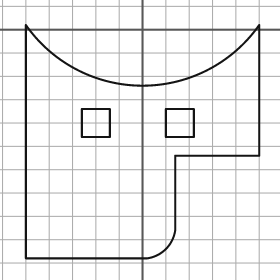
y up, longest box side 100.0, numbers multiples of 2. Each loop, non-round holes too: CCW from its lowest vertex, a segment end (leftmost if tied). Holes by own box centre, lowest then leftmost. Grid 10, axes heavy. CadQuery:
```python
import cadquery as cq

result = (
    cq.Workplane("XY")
    .moveTo(-50.0, -98.0)
    .lineTo(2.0, -98.0)
    .threePointArc((10.0, -94.0), (14.0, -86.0))
    .lineTo(14.0, -54.0)
    .lineTo(50.0, -54.0)
    .lineTo(50.0, 2.0)
    .threePointArc((0.0, -24.0), (-50.0, 2.0))
    .close()
    .moveTo(-26.0, -46.0)
    .lineTo(-14.0, -46.0)
    .lineTo(-14.0, -34.0)
    .lineTo(-26.0, -34.0)
    .close()
    .moveTo(10.0, -46.0)
    .lineTo(22.0, -46.0)
    .lineTo(22.0, -34.0)
    .lineTo(10.0, -34.0)
    .close()
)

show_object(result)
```